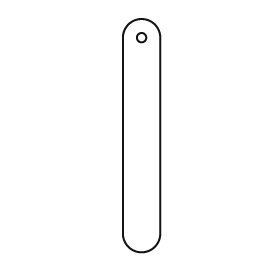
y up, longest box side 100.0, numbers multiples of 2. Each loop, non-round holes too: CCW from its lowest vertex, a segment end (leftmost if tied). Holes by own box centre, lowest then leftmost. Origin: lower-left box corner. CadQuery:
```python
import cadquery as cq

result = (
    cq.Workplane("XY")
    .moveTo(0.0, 8.0)
    .threePointArc((8.0, 0.0), (16.0, 8.0))
    .lineTo(16.0, 92.0)
    .threePointArc((8.0, 100.0), (0.0, 92.0))
    .close()
    .moveTo(8.0, 92.0)
    .circle(2.0)
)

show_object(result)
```